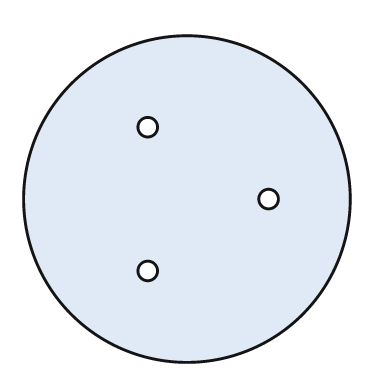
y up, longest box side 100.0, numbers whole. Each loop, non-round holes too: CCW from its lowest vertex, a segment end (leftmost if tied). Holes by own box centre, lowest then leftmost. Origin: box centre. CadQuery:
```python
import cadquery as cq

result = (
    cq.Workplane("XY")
    .moveTo(0.0, 0.0)
    .circle(50.0)
    .moveTo(-12.0, -22.0)
    .circle(3.0)
    .moveTo(25.0, 0.0)
    .circle(3.0)
    .moveTo(-12.0, 22.0)
    .circle(3.0)
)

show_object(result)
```